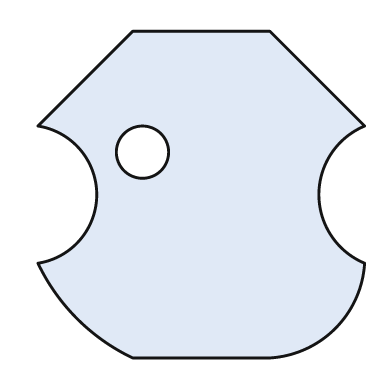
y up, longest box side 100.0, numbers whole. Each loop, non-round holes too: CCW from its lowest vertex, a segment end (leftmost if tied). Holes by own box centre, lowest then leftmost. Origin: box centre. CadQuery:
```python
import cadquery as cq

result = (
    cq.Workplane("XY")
    .moveTo(-21.0, -50.0)
    .lineTo(21.0, -50.0)
    .threePointArc((41.0, -41.0), (50.0, -21.0))
    .threePointArc((36.0, 0.0), (50.0, 21.0))
    .lineTo(21.0, 50.0)
    .lineTo(-21.0, 50.0)
    .lineTo(-50.0, 21.0)
    .threePointArc((-32.0, 0.0), (-50.0, -21.0))
    .threePointArc((-38.0, -38.0), (-21.0, -50.0))
    .close()
    .moveTo(-18.0, 13.0)
    .circle(8.0)
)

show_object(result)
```